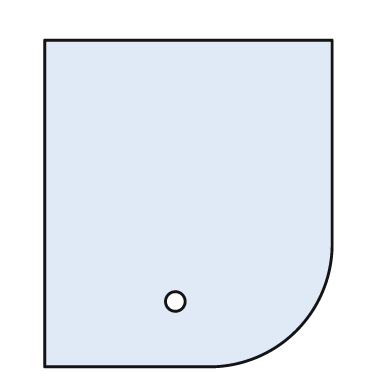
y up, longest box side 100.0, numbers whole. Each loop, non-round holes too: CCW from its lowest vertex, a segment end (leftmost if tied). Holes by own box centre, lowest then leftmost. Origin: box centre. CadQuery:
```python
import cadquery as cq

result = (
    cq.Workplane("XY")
    .moveTo(-44.0, -50.0)
    .lineTo(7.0, -50.0)
    .threePointArc((33.0, -39.0), (44.0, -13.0))
    .lineTo(44.0, 50.0)
    .lineTo(-44.0, 50.0)
    .close()
    .moveTo(-4.0, -30.0)
    .circle(3.0)
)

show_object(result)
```